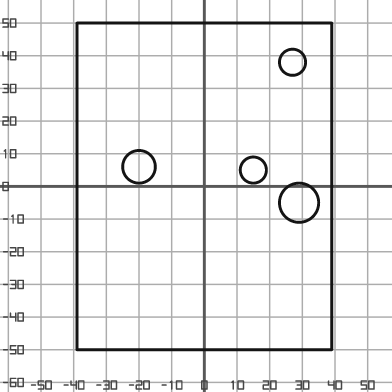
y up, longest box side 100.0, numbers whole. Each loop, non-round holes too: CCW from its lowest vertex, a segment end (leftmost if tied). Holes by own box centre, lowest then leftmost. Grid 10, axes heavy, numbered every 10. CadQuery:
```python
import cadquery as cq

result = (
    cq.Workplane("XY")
    .moveTo(-39.0, -50.0)
    .lineTo(39.0, -50.0)
    .lineTo(39.0, 50.0)
    .lineTo(-39.0, 50.0)
    .close()
    .moveTo(29.0, -5.0)
    .circle(6.0)
    .moveTo(15.0, 5.0)
    .circle(4.0)
    .moveTo(-20.0, 6.0)
    .circle(5.0)
    .moveTo(27.0, 38.0)
    .circle(4.0)
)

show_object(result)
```